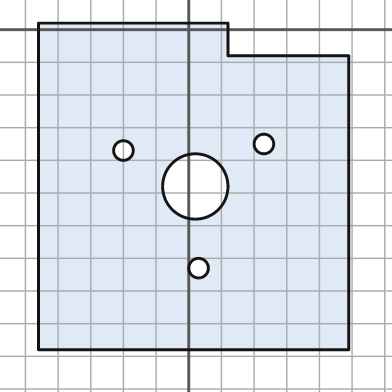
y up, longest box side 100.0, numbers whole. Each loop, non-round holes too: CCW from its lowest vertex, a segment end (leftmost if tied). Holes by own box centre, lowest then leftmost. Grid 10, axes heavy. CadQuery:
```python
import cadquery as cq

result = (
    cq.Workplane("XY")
    .moveTo(-46.0, -98.0)
    .lineTo(49.0, -98.0)
    .lineTo(49.0, -8.0)
    .lineTo(12.0, -8.0)
    .lineTo(12.0, 2.0)
    .lineTo(-46.0, 2.0)
    .close()
    .moveTo(3.0, -73.0)
    .circle(3.0)
    .moveTo(2.0, -48.0)
    .circle(10.0)
    .moveTo(-20.0, -37.0)
    .circle(3.0)
    .moveTo(23.0, -35.0)
    .circle(3.0)
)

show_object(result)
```